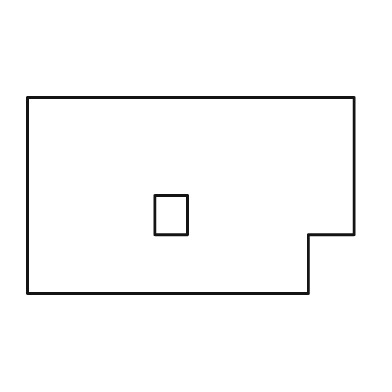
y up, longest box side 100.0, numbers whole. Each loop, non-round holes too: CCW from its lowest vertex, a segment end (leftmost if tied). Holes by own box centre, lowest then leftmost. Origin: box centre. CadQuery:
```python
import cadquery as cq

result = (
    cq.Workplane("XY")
    .moveTo(-50.0, -30.0)
    .lineTo(36.0, -30.0)
    .lineTo(36.0, -12.0)
    .lineTo(50.0, -12.0)
    .lineTo(50.0, 30.0)
    .lineTo(-50.0, 30.0)
    .close()
    .moveTo(-11.0, -12.0)
    .lineTo(-1.0, -12.0)
    .lineTo(-1.0, 0.0)
    .lineTo(-11.0, 0.0)
    .close()
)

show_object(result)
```